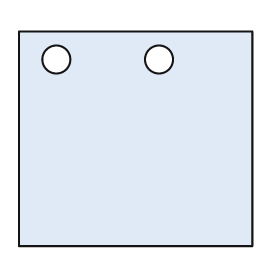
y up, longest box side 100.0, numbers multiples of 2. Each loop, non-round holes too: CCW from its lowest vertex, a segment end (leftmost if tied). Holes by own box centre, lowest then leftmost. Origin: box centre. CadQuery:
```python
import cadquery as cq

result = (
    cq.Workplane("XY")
    .moveTo(-50.0, -46.0)
    .lineTo(50.0, -46.0)
    .lineTo(50.0, 46.0)
    .lineTo(-50.0, 46.0)
    .close()
    .moveTo(-34.0, 34.0)
    .circle(6.0)
    .moveTo(10.0, 34.0)
    .circle(6.0)
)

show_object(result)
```